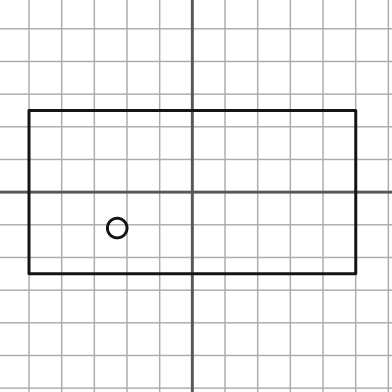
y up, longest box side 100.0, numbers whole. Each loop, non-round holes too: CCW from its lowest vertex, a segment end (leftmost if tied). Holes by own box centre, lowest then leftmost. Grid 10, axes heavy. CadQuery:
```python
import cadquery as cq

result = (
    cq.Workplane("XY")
    .moveTo(-50.0, -25.0)
    .lineTo(50.0, -25.0)
    .lineTo(50.0, 25.0)
    .lineTo(-50.0, 25.0)
    .close()
    .moveTo(-23.0, -11.0)
    .circle(3.0)
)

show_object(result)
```